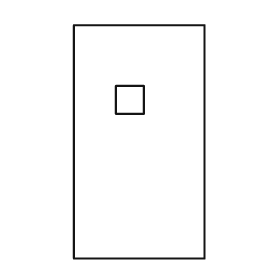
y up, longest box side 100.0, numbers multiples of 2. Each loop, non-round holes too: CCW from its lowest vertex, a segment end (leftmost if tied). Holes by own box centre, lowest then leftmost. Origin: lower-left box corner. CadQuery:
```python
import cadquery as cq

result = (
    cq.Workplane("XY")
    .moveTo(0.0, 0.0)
    .lineTo(56.0, 0.0)
    .lineTo(56.0, 100.0)
    .lineTo(0.0, 100.0)
    .close()
    .moveTo(18.0, 62.0)
    .lineTo(30.0, 62.0)
    .lineTo(30.0, 74.0)
    .lineTo(18.0, 74.0)
    .close()
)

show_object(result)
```